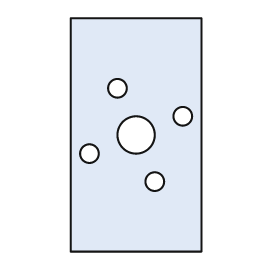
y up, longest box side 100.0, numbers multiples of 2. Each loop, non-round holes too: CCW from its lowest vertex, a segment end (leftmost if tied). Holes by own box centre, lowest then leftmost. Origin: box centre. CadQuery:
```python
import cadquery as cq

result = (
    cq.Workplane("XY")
    .moveTo(-28.0, -50.0)
    .lineTo(28.0, -50.0)
    .lineTo(28.0, 50.0)
    .lineTo(-28.0, 50.0)
    .close()
    .moveTo(8.0, -20.0)
    .circle(4.0)
    .moveTo(-20.0, -8.0)
    .circle(4.0)
    .moveTo(0.0, 0.0)
    .circle(8.0)
    .moveTo(20.0, 8.0)
    .circle(4.0)
    .moveTo(-8.0, 20.0)
    .circle(4.0)
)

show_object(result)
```